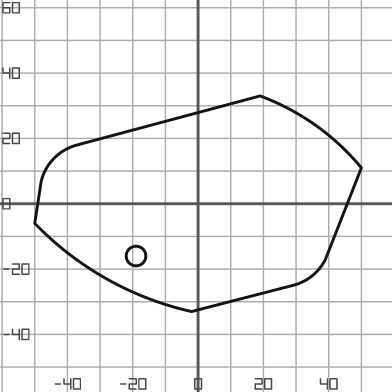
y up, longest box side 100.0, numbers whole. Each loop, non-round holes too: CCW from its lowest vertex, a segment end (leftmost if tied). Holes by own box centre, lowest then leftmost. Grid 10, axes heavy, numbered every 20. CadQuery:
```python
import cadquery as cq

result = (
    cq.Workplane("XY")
    .moveTo(-2.0, -33.0)
    .lineTo(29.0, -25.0)
    .threePointArc((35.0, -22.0), (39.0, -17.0))
    .lineTo(50.0, 11.0)
    .threePointArc((36.0, 24.0), (19.0, 33.0))
    .lineTo(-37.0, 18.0)
    .threePointArc((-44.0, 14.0), (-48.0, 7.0))
    .lineTo(-50.0, -6.0)
    .threePointArc((-28.0, -23.0), (-2.0, -33.0))
    .close()
    .moveTo(-19.0, -16.0)
    .circle(3.0)
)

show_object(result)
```